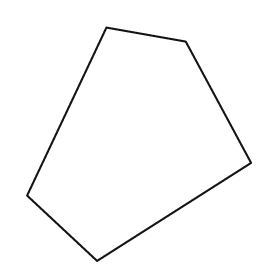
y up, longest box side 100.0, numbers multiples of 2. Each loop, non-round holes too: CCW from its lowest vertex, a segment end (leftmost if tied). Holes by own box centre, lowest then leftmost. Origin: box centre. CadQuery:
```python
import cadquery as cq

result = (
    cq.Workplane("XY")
    .moveTo(-18.0, -50.0)
    .lineTo(48.0, -8.0)
    .lineTo(20.0, 44.0)
    .lineTo(-14.0, 50.0)
    .lineTo(-48.0, -22.0)
    .close()
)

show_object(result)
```